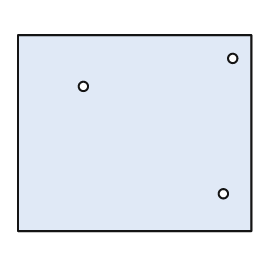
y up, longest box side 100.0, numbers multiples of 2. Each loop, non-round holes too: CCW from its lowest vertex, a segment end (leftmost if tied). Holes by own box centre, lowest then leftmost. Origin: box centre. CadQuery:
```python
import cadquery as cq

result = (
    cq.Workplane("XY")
    .moveTo(-50.0, -42.0)
    .lineTo(50.0, -42.0)
    .lineTo(50.0, 42.0)
    .lineTo(-50.0, 42.0)
    .close()
    .moveTo(38.0, -26.0)
    .circle(2.0)
    .moveTo(-22.0, 20.0)
    .circle(2.0)
    .moveTo(42.0, 32.0)
    .circle(2.0)
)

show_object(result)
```